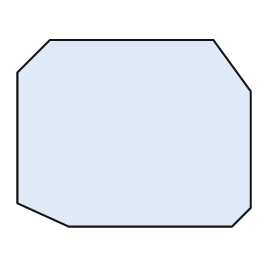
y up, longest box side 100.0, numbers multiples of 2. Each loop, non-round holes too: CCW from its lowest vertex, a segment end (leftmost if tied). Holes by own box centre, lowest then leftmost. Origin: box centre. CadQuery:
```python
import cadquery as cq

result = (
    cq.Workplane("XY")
    .moveTo(-28.0, -40.0)
    .lineTo(42.0, -40.0)
    .lineTo(50.0, -32.0)
    .lineTo(50.0, 18.0)
    .lineTo(34.0, 40.0)
    .lineTo(-36.0, 40.0)
    .lineTo(-50.0, 26.0)
    .lineTo(-50.0, -30.0)
    .close()
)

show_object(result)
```